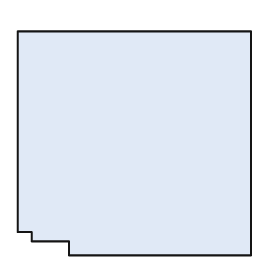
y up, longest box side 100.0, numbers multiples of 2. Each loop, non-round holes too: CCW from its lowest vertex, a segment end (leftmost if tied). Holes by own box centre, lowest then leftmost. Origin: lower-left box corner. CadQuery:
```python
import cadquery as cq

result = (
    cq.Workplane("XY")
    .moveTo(22.0, 0.0)
    .lineTo(100.0, 0.0)
    .lineTo(100.0, 96.0)
    .lineTo(0.0, 96.0)
    .lineTo(0.0, 10.0)
    .lineTo(6.0, 10.0)
    .lineTo(6.0, 6.0)
    .lineTo(22.0, 6.0)
    .close()
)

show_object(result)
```